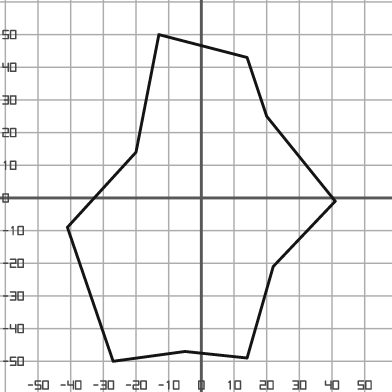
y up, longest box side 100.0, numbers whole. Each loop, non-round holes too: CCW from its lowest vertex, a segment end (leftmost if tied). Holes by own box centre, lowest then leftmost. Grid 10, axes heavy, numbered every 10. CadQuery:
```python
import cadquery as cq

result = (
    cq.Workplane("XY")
    .moveTo(-27.0, -50.0)
    .lineTo(-5.0, -47.0)
    .lineTo(14.0, -49.0)
    .lineTo(22.0, -21.0)
    .lineTo(41.0, -1.0)
    .lineTo(20.0, 25.0)
    .lineTo(14.0, 43.0)
    .lineTo(-13.0, 50.0)
    .lineTo(-20.0, 14.0)
    .lineTo(-41.0, -9.0)
    .close()
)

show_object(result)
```